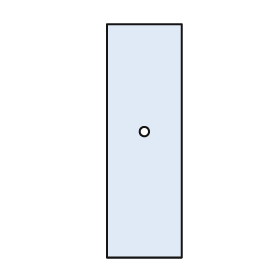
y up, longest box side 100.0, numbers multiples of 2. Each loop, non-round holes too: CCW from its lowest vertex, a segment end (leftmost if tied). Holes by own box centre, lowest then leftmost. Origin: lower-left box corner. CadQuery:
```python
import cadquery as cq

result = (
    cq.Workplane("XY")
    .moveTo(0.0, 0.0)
    .lineTo(32.0, 0.0)
    .lineTo(32.0, 100.0)
    .lineTo(0.0, 100.0)
    .close()
    .moveTo(16.0, 54.0)
    .circle(2.0)
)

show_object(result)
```